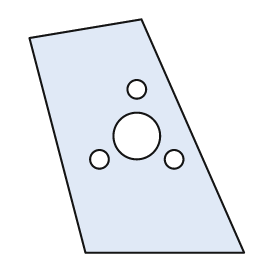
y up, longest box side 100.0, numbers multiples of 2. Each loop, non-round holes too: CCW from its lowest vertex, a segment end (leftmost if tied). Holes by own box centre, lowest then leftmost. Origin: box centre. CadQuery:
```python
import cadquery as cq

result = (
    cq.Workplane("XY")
    .moveTo(-22.0, -50.0)
    .lineTo(46.0, -50.0)
    .lineTo(2.0, 50.0)
    .lineTo(-46.0, 42.0)
    .close()
    .moveTo(-16.0, -10.0)
    .circle(4.0)
    .moveTo(16.0, -10.0)
    .circle(4.0)
    .moveTo(0.0, 0.0)
    .circle(10.0)
    .moveTo(0.0, 20.0)
    .circle(4.0)
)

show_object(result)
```